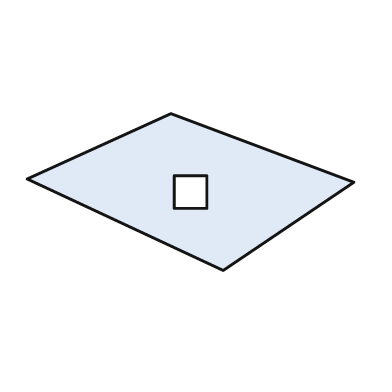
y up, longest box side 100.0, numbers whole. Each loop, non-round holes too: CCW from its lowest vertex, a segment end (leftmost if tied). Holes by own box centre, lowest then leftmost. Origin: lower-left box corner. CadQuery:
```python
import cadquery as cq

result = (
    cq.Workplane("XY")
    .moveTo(60.0, 0.0)
    .lineTo(100.0, 27.0)
    .lineTo(44.0, 48.0)
    .lineTo(0.0, 28.0)
    .close()
    .moveTo(45.0, 19.0)
    .lineTo(55.0, 19.0)
    .lineTo(55.0, 29.0)
    .lineTo(45.0, 29.0)
    .close()
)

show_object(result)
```